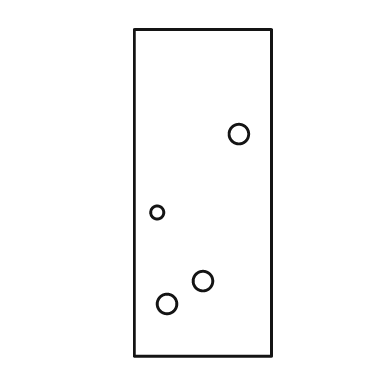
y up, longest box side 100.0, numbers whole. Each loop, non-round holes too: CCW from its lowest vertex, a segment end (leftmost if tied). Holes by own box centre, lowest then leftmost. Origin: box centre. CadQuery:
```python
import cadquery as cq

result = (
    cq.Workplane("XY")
    .moveTo(-21.0, -50.0)
    .lineTo(21.0, -50.0)
    .lineTo(21.0, 50.0)
    .lineTo(-21.0, 50.0)
    .close()
    .moveTo(-11.0, -34.0)
    .circle(3.0)
    .moveTo(0.0, -27.0)
    .circle(3.0)
    .moveTo(-14.0, -6.0)
    .circle(2.0)
    .moveTo(11.0, 18.0)
    .circle(3.0)
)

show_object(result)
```